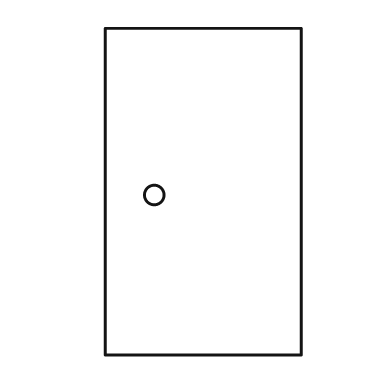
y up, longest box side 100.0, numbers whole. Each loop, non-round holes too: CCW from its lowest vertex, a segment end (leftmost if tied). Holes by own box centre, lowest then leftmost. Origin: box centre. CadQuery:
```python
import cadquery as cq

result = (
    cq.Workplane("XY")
    .moveTo(-30.0, -50.0)
    .lineTo(30.0, -50.0)
    .lineTo(30.0, 50.0)
    .lineTo(-30.0, 50.0)
    .close()
    .moveTo(-15.0, -1.0)
    .circle(3.0)
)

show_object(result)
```